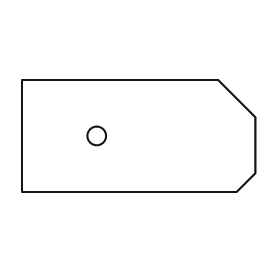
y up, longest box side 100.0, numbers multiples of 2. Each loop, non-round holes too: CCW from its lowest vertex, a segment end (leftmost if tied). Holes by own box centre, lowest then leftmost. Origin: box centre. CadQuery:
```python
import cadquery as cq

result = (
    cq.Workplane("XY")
    .moveTo(-50.0, -24.0)
    .lineTo(42.0, -24.0)
    .lineTo(50.0, -16.0)
    .lineTo(50.0, 8.0)
    .lineTo(34.0, 24.0)
    .lineTo(-50.0, 24.0)
    .close()
    .moveTo(-18.0, 0.0)
    .circle(4.0)
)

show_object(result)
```